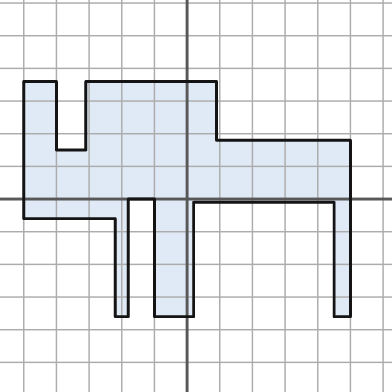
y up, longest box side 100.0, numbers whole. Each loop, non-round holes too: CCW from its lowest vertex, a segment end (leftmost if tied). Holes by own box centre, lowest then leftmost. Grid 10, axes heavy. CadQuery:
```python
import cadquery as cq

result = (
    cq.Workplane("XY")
    .moveTo(-22.0, -36.0)
    .lineTo(-18.0, -36.0)
    .lineTo(-18.0, 0.0)
    .lineTo(-10.0, 0.0)
    .lineTo(-10.0, -36.0)
    .lineTo(2.0, -36.0)
    .lineTo(2.0, -1.0)
    .lineTo(45.0, -1.0)
    .lineTo(45.0, -36.0)
    .lineTo(50.0, -36.0)
    .lineTo(50.0, 18.0)
    .lineTo(9.0, 18.0)
    .lineTo(9.0, 36.0)
    .lineTo(-31.0, 36.0)
    .lineTo(-31.0, 15.0)
    .lineTo(-40.0, 15.0)
    .lineTo(-40.0, 36.0)
    .lineTo(-50.0, 36.0)
    .lineTo(-50.0, -6.0)
    .lineTo(-22.0, -6.0)
    .close()
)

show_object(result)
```